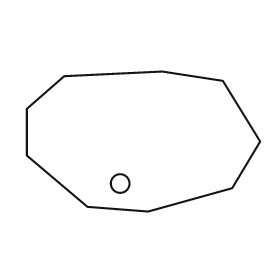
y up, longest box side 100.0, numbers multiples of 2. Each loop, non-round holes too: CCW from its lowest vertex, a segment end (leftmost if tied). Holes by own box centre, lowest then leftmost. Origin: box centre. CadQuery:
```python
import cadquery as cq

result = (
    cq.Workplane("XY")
    .moveTo(2.0, -30.0)
    .lineTo(38.0, -20.0)
    .lineTo(50.0, 0.0)
    .lineTo(34.0, 26.0)
    .lineTo(8.0, 30.0)
    .lineTo(-34.0, 28.0)
    .lineTo(-50.0, 14.0)
    .lineTo(-50.0, -6.0)
    .lineTo(-24.0, -28.0)
    .close()
    .moveTo(-10.0, -18.0)
    .circle(4.0)
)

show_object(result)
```